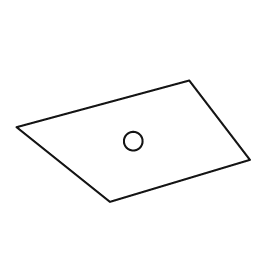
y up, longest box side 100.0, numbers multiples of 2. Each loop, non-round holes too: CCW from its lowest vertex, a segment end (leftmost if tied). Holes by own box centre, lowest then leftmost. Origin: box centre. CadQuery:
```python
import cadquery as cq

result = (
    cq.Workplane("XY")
    .moveTo(-10.0, -26.0)
    .lineTo(50.0, -8.0)
    .lineTo(24.0, 26.0)
    .lineTo(-50.0, 6.0)
    .close()
    .moveTo(0.0, 0.0)
    .circle(4.0)
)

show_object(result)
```